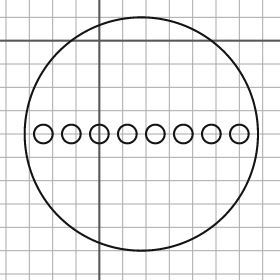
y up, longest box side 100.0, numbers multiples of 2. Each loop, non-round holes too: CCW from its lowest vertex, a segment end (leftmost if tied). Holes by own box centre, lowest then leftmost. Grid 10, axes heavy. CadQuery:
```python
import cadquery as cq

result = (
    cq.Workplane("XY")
    .moveTo(18.0, -40.0)
    .circle(50.0)
    .moveTo(-24.0, -40.0)
    .circle(4.0)
    .moveTo(-12.0, -40.0)
    .circle(4.0)
    .moveTo(0.0, -40.0)
    .circle(4.0)
    .moveTo(12.0, -40.0)
    .circle(4.0)
    .moveTo(24.0, -40.0)
    .circle(4.0)
    .moveTo(36.0, -40.0)
    .circle(4.0)
    .moveTo(48.0, -40.0)
    .circle(4.0)
    .moveTo(60.0, -40.0)
    .circle(4.0)
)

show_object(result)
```